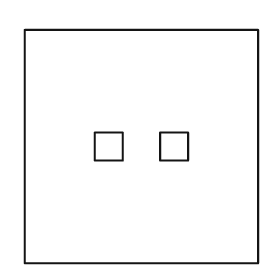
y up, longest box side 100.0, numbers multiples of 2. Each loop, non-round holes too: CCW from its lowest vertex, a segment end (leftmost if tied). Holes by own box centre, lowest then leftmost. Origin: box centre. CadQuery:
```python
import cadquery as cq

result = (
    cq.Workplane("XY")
    .moveTo(-50.0, -50.0)
    .lineTo(50.0, -50.0)
    .lineTo(50.0, 50.0)
    .lineTo(-50.0, 50.0)
    .close()
    .moveTo(-20.0, -6.0)
    .lineTo(-8.0, -6.0)
    .lineTo(-8.0, 6.0)
    .lineTo(-20.0, 6.0)
    .close()
    .moveTo(8.0, -6.0)
    .lineTo(20.0, -6.0)
    .lineTo(20.0, 6.0)
    .lineTo(8.0, 6.0)
    .close()
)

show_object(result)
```